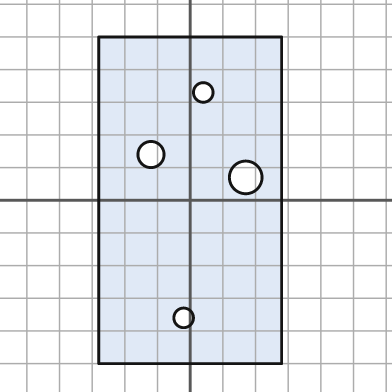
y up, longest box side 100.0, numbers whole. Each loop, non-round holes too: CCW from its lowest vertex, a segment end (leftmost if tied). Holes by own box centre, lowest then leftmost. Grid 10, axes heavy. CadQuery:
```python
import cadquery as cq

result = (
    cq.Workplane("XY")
    .moveTo(-28.0, -50.0)
    .lineTo(28.0, -50.0)
    .lineTo(28.0, 50.0)
    .lineTo(-28.0, 50.0)
    .close()
    .moveTo(-2.0, -36.0)
    .circle(3.0)
    .moveTo(17.0, 7.0)
    .circle(5.0)
    .moveTo(-12.0, 14.0)
    .circle(4.0)
    .moveTo(4.0, 33.0)
    .circle(3.0)
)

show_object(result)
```